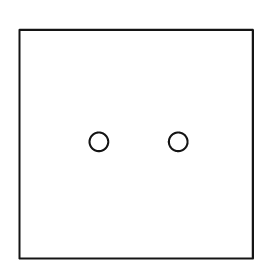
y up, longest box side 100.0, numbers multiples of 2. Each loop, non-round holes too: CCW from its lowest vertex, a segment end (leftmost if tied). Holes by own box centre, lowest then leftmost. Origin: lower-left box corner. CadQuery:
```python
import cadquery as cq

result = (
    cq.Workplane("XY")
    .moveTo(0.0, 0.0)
    .lineTo(100.0, 0.0)
    .lineTo(100.0, 98.0)
    .lineTo(0.0, 98.0)
    .close()
    .moveTo(34.0, 50.0)
    .circle(4.0)
    .moveTo(68.0, 50.0)
    .circle(4.0)
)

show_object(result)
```